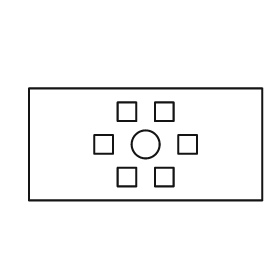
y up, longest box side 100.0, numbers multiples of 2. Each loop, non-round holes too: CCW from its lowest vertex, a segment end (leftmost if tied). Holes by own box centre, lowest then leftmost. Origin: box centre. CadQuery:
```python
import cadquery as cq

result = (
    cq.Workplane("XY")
    .moveTo(-50.0, -24.0)
    .lineTo(50.0, -24.0)
    .lineTo(50.0, 24.0)
    .lineTo(-50.0, 24.0)
    .close()
    .moveTo(-12.0, -18.0)
    .lineTo(-4.0, -18.0)
    .lineTo(-4.0, -10.0)
    .lineTo(-12.0, -10.0)
    .close()
    .moveTo(4.0, -18.0)
    .lineTo(12.0, -18.0)
    .lineTo(12.0, -10.0)
    .lineTo(4.0, -10.0)
    .close()
    .moveTo(-22.0, -4.0)
    .lineTo(-14.0, -4.0)
    .lineTo(-14.0, 4.0)
    .lineTo(-22.0, 4.0)
    .close()
    .moveTo(0.0, 0.0)
    .circle(6.0)
    .moveTo(14.0, -4.0)
    .lineTo(22.0, -4.0)
    .lineTo(22.0, 4.0)
    .lineTo(14.0, 4.0)
    .close()
    .moveTo(-12.0, 10.0)
    .lineTo(-4.0, 10.0)
    .lineTo(-4.0, 18.0)
    .lineTo(-12.0, 18.0)
    .close()
    .moveTo(4.0, 10.0)
    .lineTo(12.0, 10.0)
    .lineTo(12.0, 18.0)
    .lineTo(4.0, 18.0)
    .close()
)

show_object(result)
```